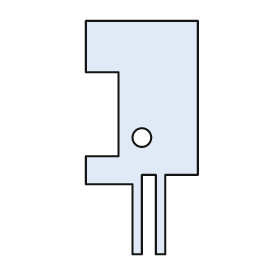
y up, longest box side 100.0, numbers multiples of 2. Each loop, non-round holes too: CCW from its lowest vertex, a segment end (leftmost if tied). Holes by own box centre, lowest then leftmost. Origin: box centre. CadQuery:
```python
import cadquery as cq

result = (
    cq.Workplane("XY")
    .moveTo(-4.0, -50.0)
    .lineTo(0.0, -50.0)
    .lineTo(0.0, -16.0)
    .lineTo(6.0, -16.0)
    .lineTo(6.0, -50.0)
    .lineTo(10.0, -50.0)
    .lineTo(10.0, -16.0)
    .lineTo(24.0, -16.0)
    .lineTo(24.0, 50.0)
    .lineTo(-24.0, 50.0)
    .lineTo(-24.0, 28.0)
    .lineTo(-10.0, 28.0)
    .lineTo(-10.0, -8.0)
    .lineTo(-24.0, -8.0)
    .lineTo(-24.0, -20.0)
    .lineTo(-4.0, -20.0)
    .close()
    .moveTo(0.0, 0.0)
    .circle(4.0)
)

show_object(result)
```